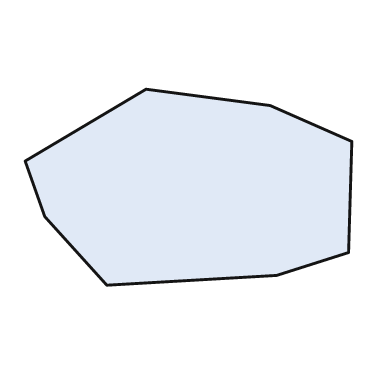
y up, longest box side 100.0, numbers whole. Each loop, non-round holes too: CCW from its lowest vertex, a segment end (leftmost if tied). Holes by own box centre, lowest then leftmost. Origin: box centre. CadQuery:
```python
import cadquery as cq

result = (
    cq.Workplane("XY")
    .moveTo(-25.0, -30.0)
    .lineTo(27.0, -27.0)
    .lineTo(49.0, -20.0)
    .lineTo(50.0, 14.0)
    .lineTo(25.0, 25.0)
    .lineTo(-13.0, 30.0)
    .lineTo(-50.0, 8.0)
    .lineTo(-44.0, -9.0)
    .close()
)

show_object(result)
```